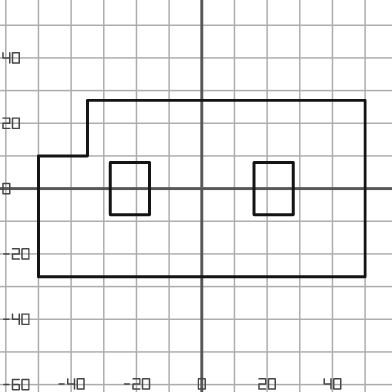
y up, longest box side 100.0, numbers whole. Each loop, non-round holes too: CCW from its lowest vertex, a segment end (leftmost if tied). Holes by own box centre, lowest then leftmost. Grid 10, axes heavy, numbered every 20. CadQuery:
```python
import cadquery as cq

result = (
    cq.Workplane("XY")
    .moveTo(-50.0, -27.0)
    .lineTo(50.0, -27.0)
    .lineTo(50.0, 27.0)
    .lineTo(-35.0, 27.0)
    .lineTo(-35.0, 10.0)
    .lineTo(-50.0, 10.0)
    .close()
    .moveTo(-28.0, -8.0)
    .lineTo(-16.0, -8.0)
    .lineTo(-16.0, 8.0)
    .lineTo(-28.0, 8.0)
    .close()
    .moveTo(16.0, -8.0)
    .lineTo(28.0, -8.0)
    .lineTo(28.0, 8.0)
    .lineTo(16.0, 8.0)
    .close()
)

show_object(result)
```